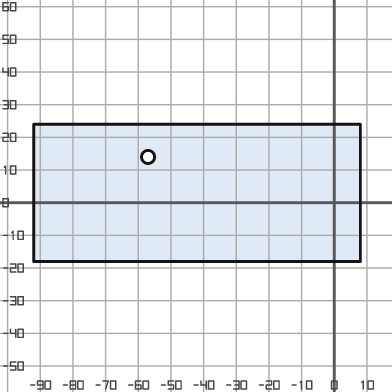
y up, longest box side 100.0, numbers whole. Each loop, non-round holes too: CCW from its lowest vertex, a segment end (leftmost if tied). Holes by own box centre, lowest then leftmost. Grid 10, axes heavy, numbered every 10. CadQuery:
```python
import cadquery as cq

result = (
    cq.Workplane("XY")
    .moveTo(-92.0, -18.0)
    .lineTo(8.0, -18.0)
    .lineTo(8.0, 24.0)
    .lineTo(-92.0, 24.0)
    .close()
    .moveTo(-57.0, 14.0)
    .circle(2.0)
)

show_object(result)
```